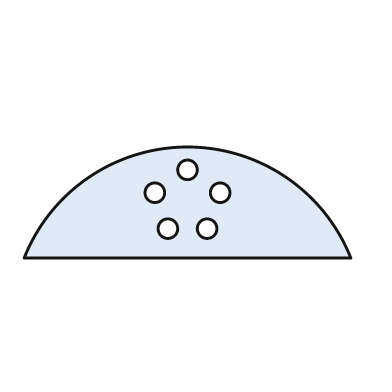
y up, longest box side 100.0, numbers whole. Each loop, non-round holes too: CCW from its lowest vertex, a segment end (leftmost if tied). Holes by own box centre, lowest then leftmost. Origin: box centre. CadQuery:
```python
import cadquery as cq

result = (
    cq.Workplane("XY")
    .moveTo(-50.0, -17.0)
    .lineTo(50.0, -17.0)
    .threePointArc((0.0, 17.0), (-50.0, -17.0))
    .close()
    .moveTo(-6.0, -8.0)
    .circle(3.0)
    .moveTo(6.0, -8.0)
    .circle(3.0)
    .moveTo(-10.0, 3.0)
    .circle(3.0)
    .moveTo(10.0, 3.0)
    .circle(3.0)
    .moveTo(0.0, 10.0)
    .circle(3.0)
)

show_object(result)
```